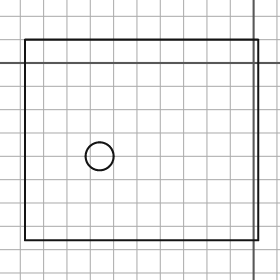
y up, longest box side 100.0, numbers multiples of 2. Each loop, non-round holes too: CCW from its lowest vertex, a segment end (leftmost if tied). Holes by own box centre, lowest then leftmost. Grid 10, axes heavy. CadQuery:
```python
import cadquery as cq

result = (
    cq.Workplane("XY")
    .moveTo(-98.0, -76.0)
    .lineTo(2.0, -76.0)
    .lineTo(2.0, 10.0)
    .lineTo(-98.0, 10.0)
    .close()
    .moveTo(-66.0, -40.0)
    .circle(6.0)
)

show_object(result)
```